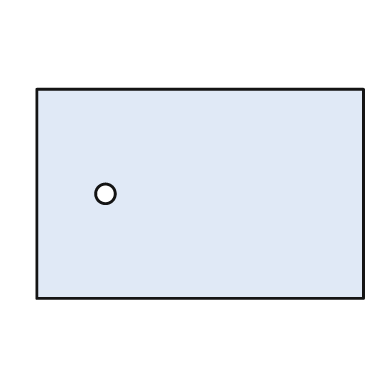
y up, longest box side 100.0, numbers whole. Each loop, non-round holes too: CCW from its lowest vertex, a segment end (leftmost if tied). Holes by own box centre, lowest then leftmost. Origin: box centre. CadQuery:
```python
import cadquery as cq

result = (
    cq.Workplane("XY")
    .moveTo(-50.0, -32.0)
    .lineTo(50.0, -32.0)
    .lineTo(50.0, 32.0)
    .lineTo(-50.0, 32.0)
    .close()
    .moveTo(-29.0, 0.0)
    .circle(3.0)
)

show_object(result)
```